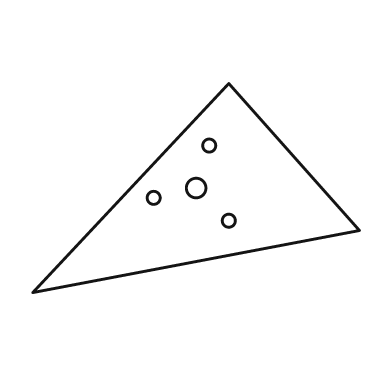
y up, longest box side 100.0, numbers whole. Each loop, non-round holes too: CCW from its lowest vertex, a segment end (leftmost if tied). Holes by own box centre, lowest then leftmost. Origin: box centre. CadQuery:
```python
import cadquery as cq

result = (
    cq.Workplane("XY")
    .moveTo(-50.0, -32.0)
    .lineTo(50.0, -13.0)
    .lineTo(10.0, 32.0)
    .close()
    .moveTo(10.0, -10.0)
    .circle(2.0)
    .moveTo(-13.0, -3.0)
    .circle(2.0)
    .moveTo(0.0, 0.0)
    .circle(3.0)
    .moveTo(4.0, 13.0)
    .circle(2.0)
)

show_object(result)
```